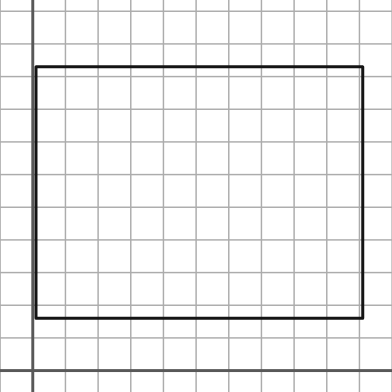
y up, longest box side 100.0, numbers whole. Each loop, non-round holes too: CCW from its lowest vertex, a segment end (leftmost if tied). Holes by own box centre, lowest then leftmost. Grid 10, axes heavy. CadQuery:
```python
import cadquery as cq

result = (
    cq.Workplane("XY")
    .moveTo(1.0, 16.0)
    .lineTo(101.0, 16.0)
    .lineTo(101.0, 93.0)
    .lineTo(1.0, 93.0)
    .close()
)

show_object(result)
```